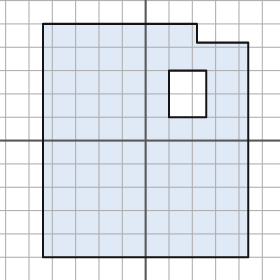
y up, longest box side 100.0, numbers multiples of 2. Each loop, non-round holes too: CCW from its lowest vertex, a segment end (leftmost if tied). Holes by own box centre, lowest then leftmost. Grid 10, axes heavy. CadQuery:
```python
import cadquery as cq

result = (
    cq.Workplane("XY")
    .moveTo(-44.0, -50.0)
    .lineTo(44.0, -50.0)
    .lineTo(44.0, 42.0)
    .lineTo(22.0, 42.0)
    .lineTo(22.0, 50.0)
    .lineTo(-44.0, 50.0)
    .close()
    .moveTo(10.0, 10.0)
    .lineTo(26.0, 10.0)
    .lineTo(26.0, 30.0)
    .lineTo(10.0, 30.0)
    .close()
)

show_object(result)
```